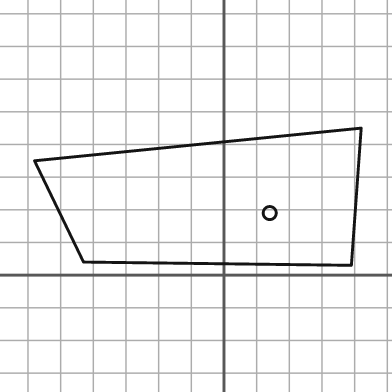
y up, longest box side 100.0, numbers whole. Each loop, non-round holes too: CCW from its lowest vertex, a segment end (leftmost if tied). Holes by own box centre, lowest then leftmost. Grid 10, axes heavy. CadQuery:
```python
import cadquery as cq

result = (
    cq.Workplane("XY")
    .moveTo(39.0, 3.0)
    .lineTo(42.0, 45.0)
    .lineTo(-58.0, 35.0)
    .lineTo(-43.0, 4.0)
    .close()
    .moveTo(14.0, 19.0)
    .circle(2.0)
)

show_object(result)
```